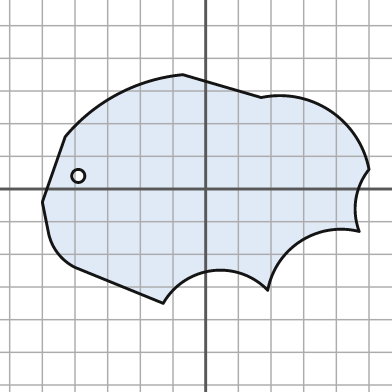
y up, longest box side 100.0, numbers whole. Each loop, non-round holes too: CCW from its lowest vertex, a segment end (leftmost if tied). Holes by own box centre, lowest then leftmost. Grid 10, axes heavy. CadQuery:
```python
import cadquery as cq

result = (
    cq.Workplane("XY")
    .moveTo(-13.0, -35.0)
    .threePointArc((2.0, -25.0), (19.0, -31.0))
    .threePointArc((29.0, -16.0), (47.0, -13.0))
    .threePointArc((46.0, -3.0), (50.0, 6.0))
    .threePointArc((38.0, 24.0), (17.0, 28.0))
    .lineTo(-7.0, 35.0)
    .threePointArc((-27.0, 29.0), (-43.0, 16.0))
    .lineTo(-50.0, -4.0)
    .lineTo(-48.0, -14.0)
    .threePointArc((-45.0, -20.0), (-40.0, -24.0))
    .close()
    .moveTo(-39.0, 4.0)
    .circle(2.0)
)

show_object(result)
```